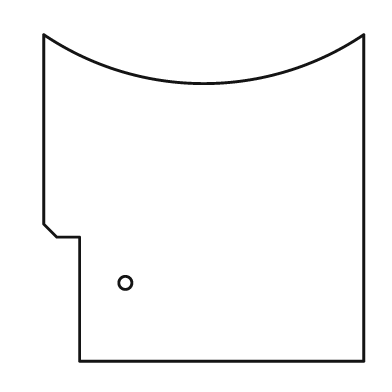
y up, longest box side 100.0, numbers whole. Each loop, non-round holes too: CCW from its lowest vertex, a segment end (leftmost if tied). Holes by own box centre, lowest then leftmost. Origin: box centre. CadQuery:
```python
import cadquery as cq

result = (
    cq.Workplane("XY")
    .moveTo(-38.0, -50.0)
    .lineTo(49.0, -50.0)
    .lineTo(49.0, 50.0)
    .threePointArc((0.0, 35.0), (-49.0, 50.0))
    .lineTo(-49.0, -8.0)
    .lineTo(-45.0, -12.0)
    .lineTo(-38.0, -12.0)
    .close()
    .moveTo(-24.0, -26.0)
    .circle(2.0)
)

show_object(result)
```